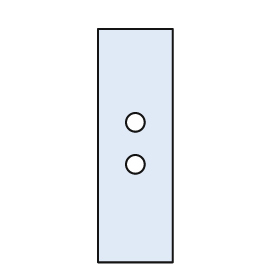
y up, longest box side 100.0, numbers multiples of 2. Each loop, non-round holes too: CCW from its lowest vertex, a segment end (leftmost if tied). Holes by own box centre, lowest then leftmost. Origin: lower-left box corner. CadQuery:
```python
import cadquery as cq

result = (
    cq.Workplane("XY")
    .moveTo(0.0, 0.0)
    .lineTo(32.0, 0.0)
    .lineTo(32.0, 100.0)
    .lineTo(0.0, 100.0)
    .close()
    .moveTo(16.0, 42.0)
    .circle(4.0)
    .moveTo(16.0, 60.0)
    .circle(4.0)
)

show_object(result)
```